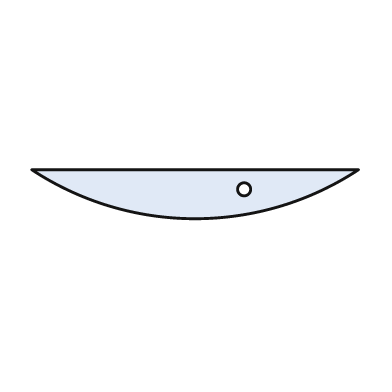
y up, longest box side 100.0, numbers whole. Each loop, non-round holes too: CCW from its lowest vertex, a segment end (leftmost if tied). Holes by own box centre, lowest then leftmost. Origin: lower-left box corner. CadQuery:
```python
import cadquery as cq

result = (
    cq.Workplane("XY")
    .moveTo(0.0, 15.0)
    .threePointArc((50.0, 0.0), (100.0, 15.0))
    .close()
    .moveTo(65.0, 9.0)
    .circle(2.0)
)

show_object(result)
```